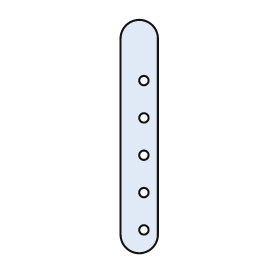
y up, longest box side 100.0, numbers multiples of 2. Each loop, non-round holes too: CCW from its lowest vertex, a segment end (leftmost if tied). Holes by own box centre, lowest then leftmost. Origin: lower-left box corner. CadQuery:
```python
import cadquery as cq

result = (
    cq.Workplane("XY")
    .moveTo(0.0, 8.0)
    .threePointArc((8.0, 0.0), (16.0, 8.0))
    .lineTo(16.0, 92.0)
    .threePointArc((8.0, 100.0), (0.0, 92.0))
    .close()
    .moveTo(10.0, 10.0)
    .circle(2.0)
    .moveTo(10.0, 26.0)
    .circle(2.0)
    .moveTo(10.0, 42.0)
    .circle(2.0)
    .moveTo(10.0, 58.0)
    .circle(2.0)
    .moveTo(10.0, 74.0)
    .circle(2.0)
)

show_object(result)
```